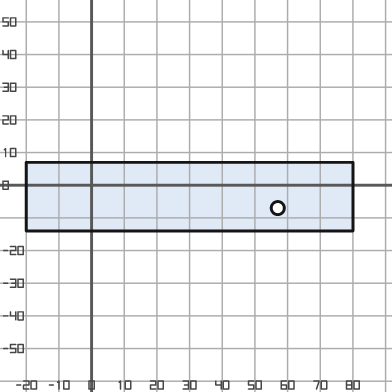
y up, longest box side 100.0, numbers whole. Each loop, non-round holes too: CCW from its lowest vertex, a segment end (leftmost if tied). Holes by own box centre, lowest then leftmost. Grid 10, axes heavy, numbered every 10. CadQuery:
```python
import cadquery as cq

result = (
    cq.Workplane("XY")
    .moveTo(-20.0, -14.0)
    .lineTo(80.0, -14.0)
    .lineTo(80.0, 7.0)
    .lineTo(-20.0, 7.0)
    .close()
    .moveTo(57.0, -7.0)
    .circle(2.0)
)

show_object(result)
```